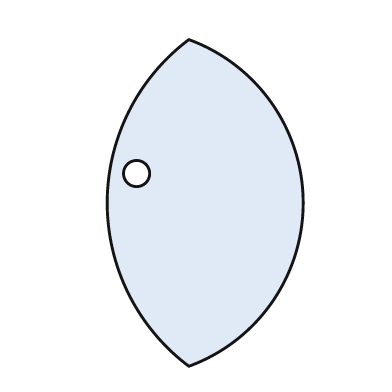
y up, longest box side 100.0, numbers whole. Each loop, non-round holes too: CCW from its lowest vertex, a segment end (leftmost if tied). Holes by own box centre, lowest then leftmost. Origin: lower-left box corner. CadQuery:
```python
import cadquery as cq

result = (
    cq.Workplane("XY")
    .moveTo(25.0, 0.0)
    .threePointArc((60.0, 50.0), (25.0, 100.0))
    .threePointArc((0.0, 50.0), (25.0, 0.0))
    .close()
    .moveTo(9.0, 59.0)
    .circle(4.0)
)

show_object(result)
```